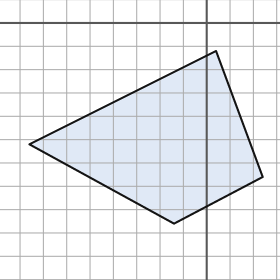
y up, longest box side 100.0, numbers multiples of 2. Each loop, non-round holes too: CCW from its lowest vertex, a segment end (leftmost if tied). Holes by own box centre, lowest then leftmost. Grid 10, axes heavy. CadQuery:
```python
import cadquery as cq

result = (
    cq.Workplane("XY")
    .moveTo(-14.0, -86.0)
    .lineTo(24.0, -66.0)
    .lineTo(4.0, -12.0)
    .lineTo(-76.0, -52.0)
    .close()
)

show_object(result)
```